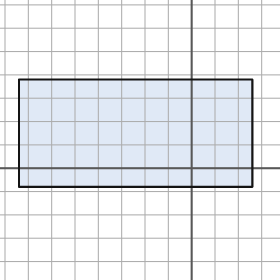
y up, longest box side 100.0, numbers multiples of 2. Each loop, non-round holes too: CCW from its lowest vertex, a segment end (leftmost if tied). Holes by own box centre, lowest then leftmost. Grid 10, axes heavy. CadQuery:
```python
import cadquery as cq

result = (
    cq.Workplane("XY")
    .moveTo(-74.0, -8.0)
    .lineTo(26.0, -8.0)
    .lineTo(26.0, 38.0)
    .lineTo(-74.0, 38.0)
    .close()
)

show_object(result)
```